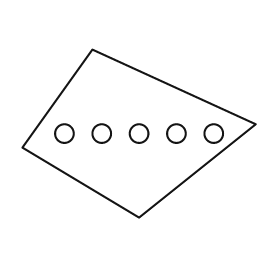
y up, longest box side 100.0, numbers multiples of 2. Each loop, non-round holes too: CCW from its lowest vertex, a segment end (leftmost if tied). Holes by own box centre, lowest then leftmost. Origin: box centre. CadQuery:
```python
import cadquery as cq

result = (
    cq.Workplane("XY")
    .moveTo(0.0, -36.0)
    .lineTo(50.0, 4.0)
    .lineTo(-20.0, 36.0)
    .lineTo(-50.0, -6.0)
    .close()
    .moveTo(-32.0, 0.0)
    .circle(4.0)
    .moveTo(-16.0, 0.0)
    .circle(4.0)
    .moveTo(0.0, 0.0)
    .circle(4.0)
    .moveTo(16.0, 0.0)
    .circle(4.0)
    .moveTo(32.0, 0.0)
    .circle(4.0)
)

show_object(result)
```